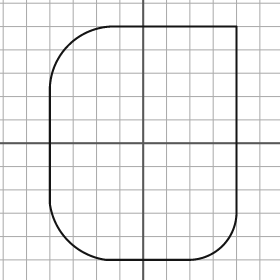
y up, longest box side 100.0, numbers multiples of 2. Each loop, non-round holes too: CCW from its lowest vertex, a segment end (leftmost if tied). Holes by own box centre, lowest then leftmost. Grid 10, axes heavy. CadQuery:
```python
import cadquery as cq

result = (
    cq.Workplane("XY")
    .moveTo(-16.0, -50.0)
    .lineTo(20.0, -50.0)
    .threePointArc((34.0, -44.0), (40.0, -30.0))
    .lineTo(40.0, 50.0)
    .lineTo(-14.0, 50.0)
    .threePointArc((-32.0, 42.0), (-40.0, 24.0))
    .lineTo(-40.0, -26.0)
    .threePointArc((-32.0, -42.0), (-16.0, -50.0))
    .close()
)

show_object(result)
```